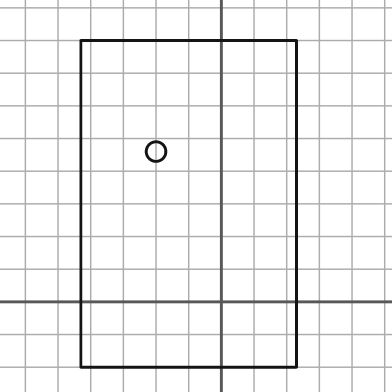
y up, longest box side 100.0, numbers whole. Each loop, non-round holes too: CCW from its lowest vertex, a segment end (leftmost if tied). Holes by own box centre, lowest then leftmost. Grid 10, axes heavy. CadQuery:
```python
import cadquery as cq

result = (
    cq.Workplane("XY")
    .moveTo(-43.0, -20.0)
    .lineTo(23.0, -20.0)
    .lineTo(23.0, 80.0)
    .lineTo(-43.0, 80.0)
    .close()
    .moveTo(-20.0, 46.0)
    .circle(3.0)
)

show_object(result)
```